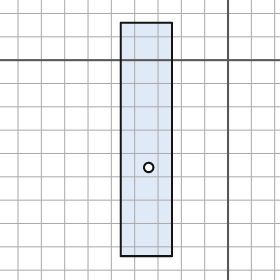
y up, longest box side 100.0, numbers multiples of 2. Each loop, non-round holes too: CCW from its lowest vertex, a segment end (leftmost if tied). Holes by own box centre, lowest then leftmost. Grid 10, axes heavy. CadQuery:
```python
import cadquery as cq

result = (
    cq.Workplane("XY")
    .moveTo(-46.0, -84.0)
    .lineTo(-24.0, -84.0)
    .lineTo(-24.0, 16.0)
    .lineTo(-46.0, 16.0)
    .close()
    .moveTo(-34.0, -46.0)
    .circle(2.0)
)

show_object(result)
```